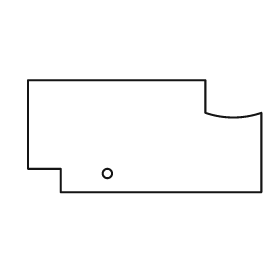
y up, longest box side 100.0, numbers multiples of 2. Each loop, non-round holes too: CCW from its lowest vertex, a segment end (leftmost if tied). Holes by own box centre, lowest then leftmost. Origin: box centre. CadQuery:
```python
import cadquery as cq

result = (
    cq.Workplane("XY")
    .moveTo(-36.0, -24.0)
    .lineTo(50.0, -24.0)
    .lineTo(50.0, 10.0)
    .threePointArc((38.0, 8.0), (26.0, 10.0))
    .lineTo(26.0, 24.0)
    .lineTo(-50.0, 24.0)
    .lineTo(-50.0, -14.0)
    .lineTo(-36.0, -14.0)
    .close()
    .moveTo(-16.0, -16.0)
    .circle(2.0)
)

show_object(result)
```